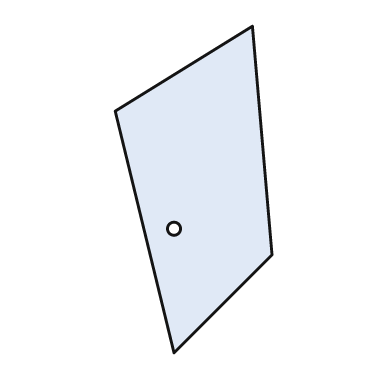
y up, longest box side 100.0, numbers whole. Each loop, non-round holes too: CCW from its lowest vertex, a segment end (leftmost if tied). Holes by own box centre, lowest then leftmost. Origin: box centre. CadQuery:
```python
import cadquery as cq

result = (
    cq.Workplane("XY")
    .moveTo(-6.0, -50.0)
    .lineTo(24.0, -20.0)
    .lineTo(18.0, 50.0)
    .lineTo(-24.0, 24.0)
    .close()
    .moveTo(-6.0, -12.0)
    .circle(2.0)
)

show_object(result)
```